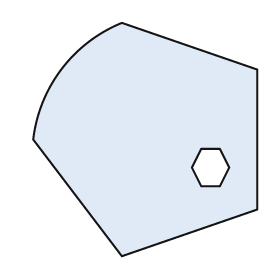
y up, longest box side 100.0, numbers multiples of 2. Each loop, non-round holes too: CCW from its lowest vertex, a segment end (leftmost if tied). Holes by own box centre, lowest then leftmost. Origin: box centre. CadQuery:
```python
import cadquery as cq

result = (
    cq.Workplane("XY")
    .moveTo(-10.0, -50.0)
    .lineTo(48.0, -30.0)
    .lineTo(48.0, 30.0)
    .lineTo(-10.0, 50.0)
    .threePointArc((-36.0, 30.0), (-48.0, 0.0))
    .close()
    .moveTo(24.0, -20.0)
    .lineTo(32.0, -20.0)
    .lineTo(36.0, -12.0)
    .lineTo(32.0, -4.0)
    .lineTo(24.0, -4.0)
    .lineTo(20.0, -12.0)
    .close()
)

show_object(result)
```